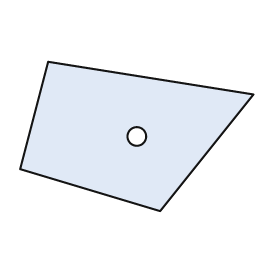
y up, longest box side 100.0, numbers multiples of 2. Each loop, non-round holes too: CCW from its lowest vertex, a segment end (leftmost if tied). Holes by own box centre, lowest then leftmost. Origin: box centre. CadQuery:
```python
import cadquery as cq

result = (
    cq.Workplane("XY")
    .moveTo(10.0, -32.0)
    .lineTo(50.0, 18.0)
    .lineTo(-38.0, 32.0)
    .lineTo(-50.0, -14.0)
    .close()
    .moveTo(0.0, 0.0)
    .circle(4.0)
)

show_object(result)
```